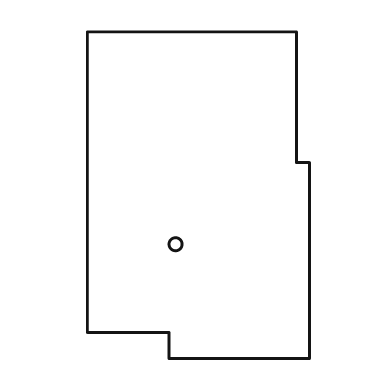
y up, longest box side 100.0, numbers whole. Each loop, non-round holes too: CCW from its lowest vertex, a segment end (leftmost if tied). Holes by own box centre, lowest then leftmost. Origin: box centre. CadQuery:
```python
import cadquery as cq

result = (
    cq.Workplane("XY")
    .moveTo(-9.0, -50.0)
    .lineTo(34.0, -50.0)
    .lineTo(34.0, 10.0)
    .lineTo(30.0, 10.0)
    .lineTo(30.0, 50.0)
    .lineTo(-34.0, 50.0)
    .lineTo(-34.0, -42.0)
    .lineTo(-9.0, -42.0)
    .close()
    .moveTo(-7.0, -15.0)
    .circle(2.0)
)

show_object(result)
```